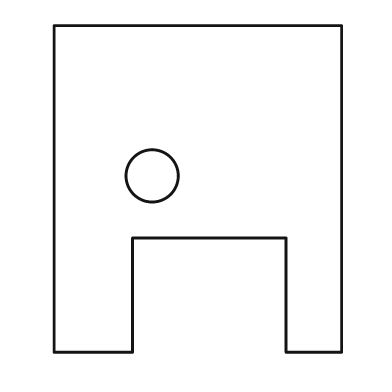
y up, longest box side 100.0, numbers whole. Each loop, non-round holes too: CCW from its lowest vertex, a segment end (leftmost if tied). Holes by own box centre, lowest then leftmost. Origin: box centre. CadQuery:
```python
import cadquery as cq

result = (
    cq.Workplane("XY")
    .moveTo(-44.0, -50.0)
    .lineTo(-20.0, -50.0)
    .lineTo(-20.0, -15.0)
    .lineTo(27.0, -15.0)
    .lineTo(27.0, -50.0)
    .lineTo(44.0, -50.0)
    .lineTo(44.0, 50.0)
    .lineTo(-44.0, 50.0)
    .close()
    .moveTo(-14.0, 4.0)
    .circle(8.0)
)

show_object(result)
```